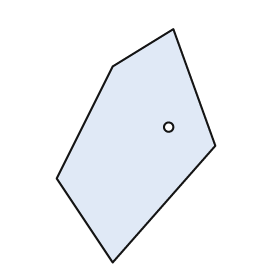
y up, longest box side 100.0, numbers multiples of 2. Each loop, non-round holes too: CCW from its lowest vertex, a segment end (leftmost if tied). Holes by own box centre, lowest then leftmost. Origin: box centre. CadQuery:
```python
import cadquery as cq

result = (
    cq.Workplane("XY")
    .moveTo(-10.0, -50.0)
    .lineTo(34.0, 0.0)
    .lineTo(16.0, 50.0)
    .lineTo(-10.0, 34.0)
    .lineTo(-34.0, -14.0)
    .close()
    .moveTo(14.0, 8.0)
    .circle(2.0)
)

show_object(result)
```